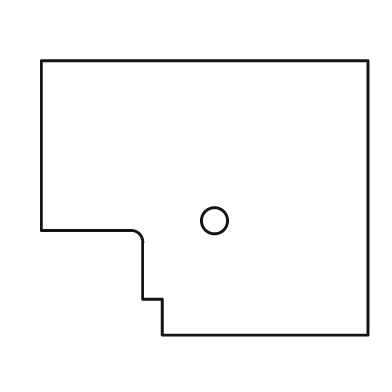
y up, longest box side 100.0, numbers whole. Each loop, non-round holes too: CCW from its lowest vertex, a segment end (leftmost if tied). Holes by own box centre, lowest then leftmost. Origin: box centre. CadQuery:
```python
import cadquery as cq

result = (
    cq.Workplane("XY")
    .moveTo(-13.0, -42.0)
    .lineTo(50.0, -42.0)
    .lineTo(50.0, 42.0)
    .lineTo(-50.0, 42.0)
    .lineTo(-50.0, -10.0)
    .lineTo(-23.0, -10.0)
    .threePointArc((-20.0, -11.0), (-19.0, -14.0))
    .lineTo(-19.0, -31.0)
    .lineTo(-13.0, -31.0)
    .close()
    .moveTo(3.0, -7.0)
    .circle(4.0)
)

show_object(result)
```